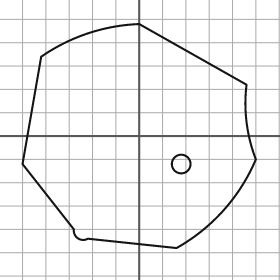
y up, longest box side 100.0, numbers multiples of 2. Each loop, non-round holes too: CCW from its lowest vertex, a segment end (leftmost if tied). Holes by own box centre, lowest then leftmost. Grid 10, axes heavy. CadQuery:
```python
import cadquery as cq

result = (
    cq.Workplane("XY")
    .moveTo(16.0, -48.0)
    .threePointArc((36.0, -32.0), (50.0, -10.0))
    .threePointArc((46.0, 6.0), (46.0, 22.0))
    .lineTo(0.0, 48.0)
    .threePointArc((-22.0, 44.0), (-42.0, 34.0))
    .lineTo(-50.0, -12.0)
    .lineTo(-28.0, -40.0)
    .threePointArc((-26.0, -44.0), (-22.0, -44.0))
    .close()
    .moveTo(18.0, -12.0)
    .circle(4.0)
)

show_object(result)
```